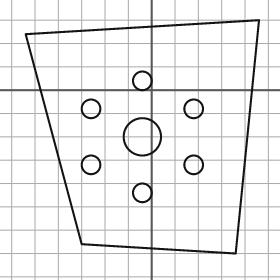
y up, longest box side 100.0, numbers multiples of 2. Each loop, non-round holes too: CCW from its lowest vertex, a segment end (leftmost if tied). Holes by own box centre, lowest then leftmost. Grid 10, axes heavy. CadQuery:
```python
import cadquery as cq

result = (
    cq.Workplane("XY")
    .moveTo(36.0, -70.0)
    .lineTo(46.0, 30.0)
    .lineTo(-54.0, 24.0)
    .lineTo(-30.0, -66.0)
    .close()
    .moveTo(-4.0, -44.0)
    .circle(4.0)
    .moveTo(-26.0, -32.0)
    .circle(4.0)
    .moveTo(18.0, -32.0)
    .circle(4.0)
    .moveTo(-4.0, -20.0)
    .circle(8.0)
    .moveTo(-26.0, -8.0)
    .circle(4.0)
    .moveTo(18.0, -8.0)
    .circle(4.0)
    .moveTo(-4.0, 4.0)
    .circle(4.0)
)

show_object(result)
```